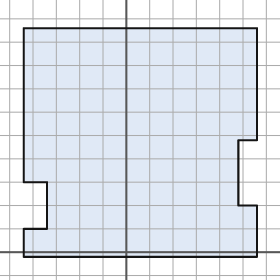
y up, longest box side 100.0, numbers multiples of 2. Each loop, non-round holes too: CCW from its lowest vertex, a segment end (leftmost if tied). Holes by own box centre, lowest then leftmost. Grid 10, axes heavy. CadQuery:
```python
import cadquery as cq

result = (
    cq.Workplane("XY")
    .moveTo(-44.0, -2.0)
    .lineTo(56.0, -2.0)
    .lineTo(56.0, 20.0)
    .lineTo(48.0, 20.0)
    .lineTo(48.0, 48.0)
    .lineTo(56.0, 48.0)
    .lineTo(56.0, 96.0)
    .lineTo(-44.0, 96.0)
    .lineTo(-44.0, 30.0)
    .lineTo(-34.0, 30.0)
    .lineTo(-34.0, 10.0)
    .lineTo(-44.0, 10.0)
    .close()
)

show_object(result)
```